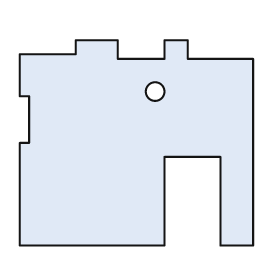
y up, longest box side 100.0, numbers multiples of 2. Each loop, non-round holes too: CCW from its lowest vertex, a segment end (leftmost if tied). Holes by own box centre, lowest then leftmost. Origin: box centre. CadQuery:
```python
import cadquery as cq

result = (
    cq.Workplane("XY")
    .moveTo(-50.0, -44.0)
    .lineTo(12.0, -44.0)
    .lineTo(12.0, -6.0)
    .lineTo(36.0, -6.0)
    .lineTo(36.0, -44.0)
    .lineTo(50.0, -44.0)
    .lineTo(50.0, 36.0)
    .lineTo(22.0, 36.0)
    .lineTo(22.0, 44.0)
    .lineTo(12.0, 44.0)
    .lineTo(12.0, 36.0)
    .lineTo(-8.0, 36.0)
    .lineTo(-8.0, 44.0)
    .lineTo(-26.0, 44.0)
    .lineTo(-26.0, 38.0)
    .lineTo(-50.0, 38.0)
    .lineTo(-50.0, 20.0)
    .lineTo(-46.0, 20.0)
    .lineTo(-46.0, 0.0)
    .lineTo(-50.0, 0.0)
    .close()
    .moveTo(8.0, 22.0)
    .circle(4.0)
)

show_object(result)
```